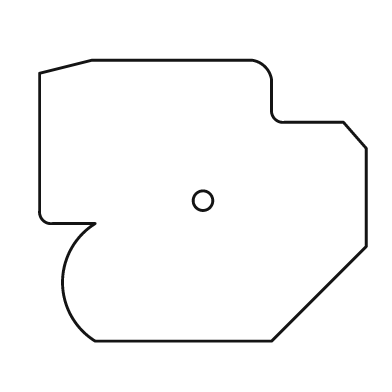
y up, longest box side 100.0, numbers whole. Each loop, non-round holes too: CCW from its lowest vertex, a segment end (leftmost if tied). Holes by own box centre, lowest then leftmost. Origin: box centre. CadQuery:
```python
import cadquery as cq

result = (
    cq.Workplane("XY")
    .moveTo(-33.0, -43.0)
    .lineTo(21.0, -43.0)
    .lineTo(50.0, -14.0)
    .lineTo(50.0, 16.0)
    .lineTo(43.0, 24.0)
    .lineTo(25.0, 24.0)
    .threePointArc((22.0, 25.0), (21.0, 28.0))
    .lineTo(21.0, 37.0)
    .threePointArc((19.0, 41.0), (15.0, 43.0))
    .lineTo(-34.0, 43.0)
    .lineTo(-50.0, 39.0)
    .lineTo(-50.0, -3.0)
    .threePointArc((-49.0, -6.0), (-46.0, -7.0))
    .lineTo(-33.0, -7.0)
    .threePointArc((-43.0, -25.0), (-33.0, -43.0))
    .close()
    .moveTo(0.0, 0.0)
    .circle(3.0)
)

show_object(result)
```